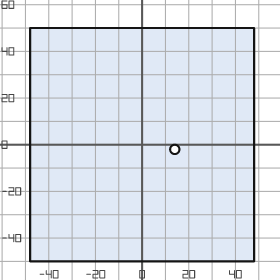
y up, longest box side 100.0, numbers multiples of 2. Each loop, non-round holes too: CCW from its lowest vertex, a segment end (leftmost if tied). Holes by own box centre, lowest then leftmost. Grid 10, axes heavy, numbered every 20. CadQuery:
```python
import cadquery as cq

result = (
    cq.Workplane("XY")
    .moveTo(-48.0, -50.0)
    .lineTo(48.0, -50.0)
    .lineTo(48.0, 50.0)
    .lineTo(-48.0, 50.0)
    .close()
    .moveTo(14.0, -2.0)
    .circle(2.0)
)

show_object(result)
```